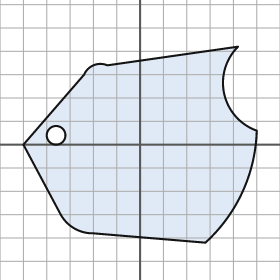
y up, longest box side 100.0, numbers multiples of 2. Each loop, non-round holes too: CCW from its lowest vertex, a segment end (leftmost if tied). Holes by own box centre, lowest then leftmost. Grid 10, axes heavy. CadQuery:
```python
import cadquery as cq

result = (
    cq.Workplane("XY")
    .moveTo(28.0, -42.0)
    .threePointArc((44.0, -20.0), (50.0, 6.0))
    .threePointArc((36.0, 22.0), (42.0, 42.0))
    .lineTo(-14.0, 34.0)
    .threePointArc((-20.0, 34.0), (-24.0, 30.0))
    .lineTo(-50.0, 0.0)
    .lineTo(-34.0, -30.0)
    .threePointArc((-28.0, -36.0), (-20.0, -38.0))
    .close()
    .moveTo(-36.0, 4.0)
    .circle(4.0)
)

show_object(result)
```